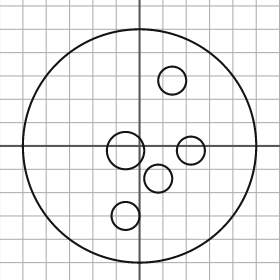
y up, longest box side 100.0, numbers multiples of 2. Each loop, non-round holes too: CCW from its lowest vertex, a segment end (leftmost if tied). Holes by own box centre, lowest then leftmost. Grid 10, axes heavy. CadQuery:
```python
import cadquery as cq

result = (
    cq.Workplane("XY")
    .moveTo(0.0, 0.0)
    .circle(50.0)
    .moveTo(-6.0, -30.0)
    .circle(6.0)
    .moveTo(8.0, -14.0)
    .circle(6.0)
    .moveTo(-6.0, -2.0)
    .circle(8.0)
    .moveTo(22.0, -2.0)
    .circle(6.0)
    .moveTo(14.0, 28.0)
    .circle(6.0)
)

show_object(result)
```